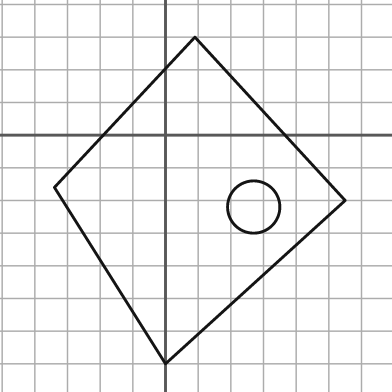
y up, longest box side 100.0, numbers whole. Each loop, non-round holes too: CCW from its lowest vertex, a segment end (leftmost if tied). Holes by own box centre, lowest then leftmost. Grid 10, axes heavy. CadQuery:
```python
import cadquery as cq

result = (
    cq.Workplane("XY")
    .moveTo(0.0, -70.0)
    .lineTo(55.0, -20.0)
    .lineTo(9.0, 30.0)
    .lineTo(-34.0, -16.0)
    .close()
    .moveTo(27.0, -22.0)
    .circle(8.0)
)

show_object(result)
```